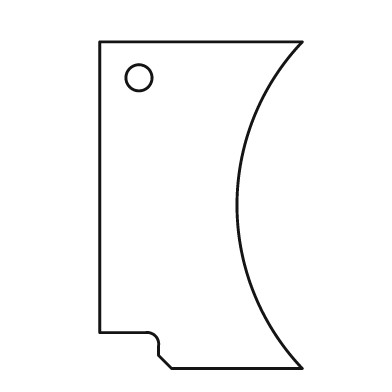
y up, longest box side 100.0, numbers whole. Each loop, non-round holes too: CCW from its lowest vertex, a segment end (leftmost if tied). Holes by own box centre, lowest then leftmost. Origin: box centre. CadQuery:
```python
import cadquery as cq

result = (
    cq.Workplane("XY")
    .moveTo(-9.0, -50.0)
    .lineTo(31.0, -50.0)
    .threePointArc((11.0, 0.0), (31.0, 50.0))
    .lineTo(-31.0, 50.0)
    .lineTo(-31.0, -39.0)
    .lineTo(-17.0, -39.0)
    .threePointArc((-14.0, -40.0), (-13.0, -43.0))
    .lineTo(-13.0, -46.0)
    .close()
    .moveTo(-19.0, 39.0)
    .circle(4.0)
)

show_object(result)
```